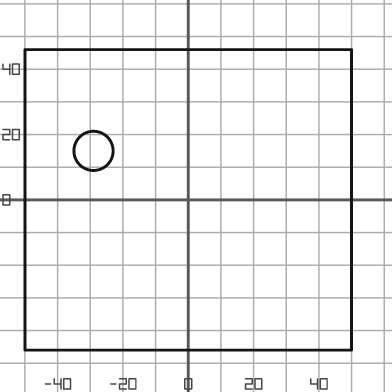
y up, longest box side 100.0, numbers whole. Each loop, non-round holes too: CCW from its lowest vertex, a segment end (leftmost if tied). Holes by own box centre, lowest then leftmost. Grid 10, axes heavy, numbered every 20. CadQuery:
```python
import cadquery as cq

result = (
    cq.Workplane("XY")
    .moveTo(-50.0, -46.0)
    .lineTo(50.0, -46.0)
    .lineTo(50.0, 46.0)
    .lineTo(-50.0, 46.0)
    .close()
    .moveTo(-29.0, 15.0)
    .circle(6.0)
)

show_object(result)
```